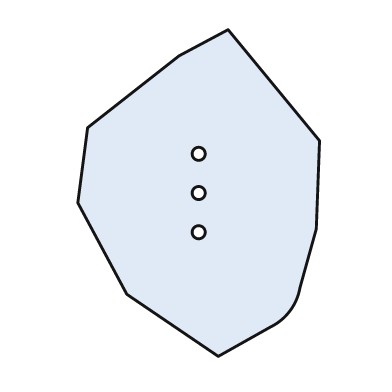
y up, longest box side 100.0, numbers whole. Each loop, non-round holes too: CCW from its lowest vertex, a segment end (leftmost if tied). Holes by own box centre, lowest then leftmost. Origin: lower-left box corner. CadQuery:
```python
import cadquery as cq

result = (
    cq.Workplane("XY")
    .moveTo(43.0, 0.0)
    .lineTo(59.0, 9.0)
    .threePointArc((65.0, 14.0), (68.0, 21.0))
    .lineTo(73.0, 39.0)
    .lineTo(74.0, 66.0)
    .lineTo(46.0, 100.0)
    .lineTo(31.0, 92.0)
    .lineTo(3.0, 70.0)
    .lineTo(0.0, 47.0)
    .lineTo(15.0, 19.0)
    .close()
    .moveTo(37.0, 38.0)
    .circle(2.0)
    .moveTo(37.0, 50.0)
    .circle(2.0)
    .moveTo(37.0, 62.0)
    .circle(2.0)
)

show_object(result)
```